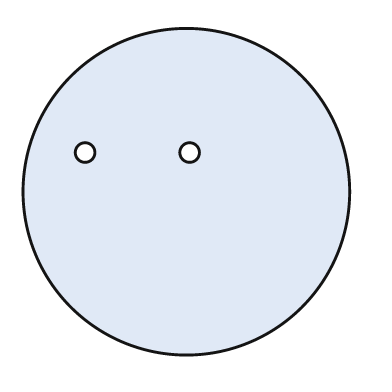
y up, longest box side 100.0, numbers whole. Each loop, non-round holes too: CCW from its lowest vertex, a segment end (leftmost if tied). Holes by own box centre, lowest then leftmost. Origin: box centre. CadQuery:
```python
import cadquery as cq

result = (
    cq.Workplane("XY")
    .moveTo(0.0, 0.0)
    .circle(50.0)
    .moveTo(-31.0, 12.0)
    .circle(3.0)
    .moveTo(1.0, 12.0)
    .circle(3.0)
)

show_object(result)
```